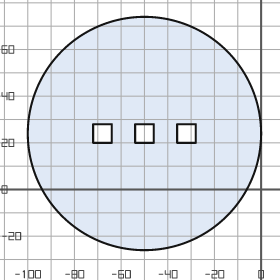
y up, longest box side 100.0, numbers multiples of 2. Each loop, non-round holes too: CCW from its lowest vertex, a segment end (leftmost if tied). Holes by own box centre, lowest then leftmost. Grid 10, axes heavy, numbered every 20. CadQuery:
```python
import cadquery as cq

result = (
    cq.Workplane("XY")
    .moveTo(-50.0, 24.0)
    .circle(50.0)
    .moveTo(-72.0, 20.0)
    .lineTo(-64.0, 20.0)
    .lineTo(-64.0, 28.0)
    .lineTo(-72.0, 28.0)
    .close()
    .moveTo(-54.0, 20.0)
    .lineTo(-46.0, 20.0)
    .lineTo(-46.0, 28.0)
    .lineTo(-54.0, 28.0)
    .close()
    .moveTo(-36.0, 20.0)
    .lineTo(-28.0, 20.0)
    .lineTo(-28.0, 28.0)
    .lineTo(-36.0, 28.0)
    .close()
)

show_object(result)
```